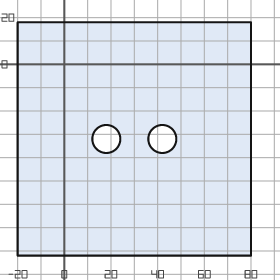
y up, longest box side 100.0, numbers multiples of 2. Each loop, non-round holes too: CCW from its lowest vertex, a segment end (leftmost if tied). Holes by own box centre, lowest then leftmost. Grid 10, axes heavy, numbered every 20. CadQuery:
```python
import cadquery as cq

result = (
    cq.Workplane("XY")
    .moveTo(-20.0, -82.0)
    .lineTo(80.0, -82.0)
    .lineTo(80.0, 18.0)
    .lineTo(-20.0, 18.0)
    .close()
    .moveTo(18.0, -32.0)
    .circle(6.0)
    .moveTo(42.0, -32.0)
    .circle(6.0)
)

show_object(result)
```